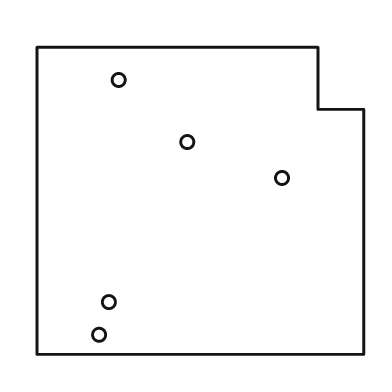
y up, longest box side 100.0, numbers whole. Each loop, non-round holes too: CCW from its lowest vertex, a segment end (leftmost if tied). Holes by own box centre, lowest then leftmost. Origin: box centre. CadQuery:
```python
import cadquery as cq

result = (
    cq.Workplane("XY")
    .moveTo(-50.0, -47.0)
    .lineTo(50.0, -47.0)
    .lineTo(50.0, 28.0)
    .lineTo(36.0, 28.0)
    .lineTo(36.0, 47.0)
    .lineTo(-50.0, 47.0)
    .close()
    .moveTo(-31.0, -41.0)
    .circle(2.0)
    .moveTo(-28.0, -31.0)
    .circle(2.0)
    .moveTo(25.0, 7.0)
    .circle(2.0)
    .moveTo(-4.0, 18.0)
    .circle(2.0)
    .moveTo(-25.0, 37.0)
    .circle(2.0)
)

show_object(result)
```